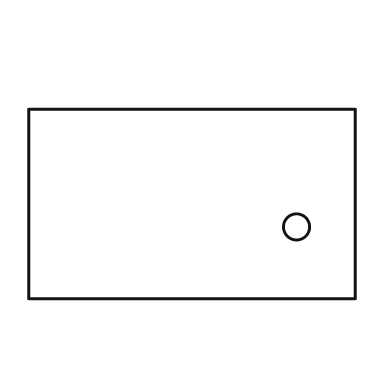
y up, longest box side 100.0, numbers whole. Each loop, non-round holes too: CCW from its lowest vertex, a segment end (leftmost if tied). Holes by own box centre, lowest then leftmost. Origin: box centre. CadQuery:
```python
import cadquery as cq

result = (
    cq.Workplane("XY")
    .moveTo(-50.0, -29.0)
    .lineTo(50.0, -29.0)
    .lineTo(50.0, 29.0)
    .lineTo(-50.0, 29.0)
    .close()
    .moveTo(32.0, -7.0)
    .circle(4.0)
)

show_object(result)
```